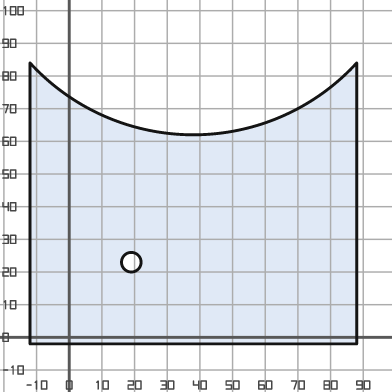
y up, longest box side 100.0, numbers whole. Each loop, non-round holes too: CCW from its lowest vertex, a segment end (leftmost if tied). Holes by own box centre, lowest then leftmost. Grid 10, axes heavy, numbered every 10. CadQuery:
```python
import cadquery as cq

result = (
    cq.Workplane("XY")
    .moveTo(-12.0, -2.0)
    .lineTo(88.0, -2.0)
    .lineTo(88.0, 84.0)
    .threePointArc((38.0, 62.0), (-12.0, 84.0))
    .close()
    .moveTo(19.0, 23.0)
    .circle(3.0)
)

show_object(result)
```